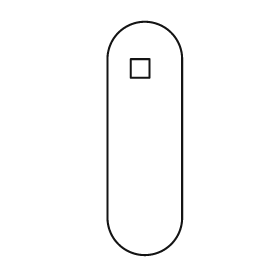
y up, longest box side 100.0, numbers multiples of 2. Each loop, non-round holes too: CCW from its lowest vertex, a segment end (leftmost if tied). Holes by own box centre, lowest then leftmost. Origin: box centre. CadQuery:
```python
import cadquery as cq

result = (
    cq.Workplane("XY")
    .moveTo(-16.0, -34.0)
    .threePointArc((0.0, -50.0), (16.0, -34.0))
    .lineTo(16.0, 34.0)
    .threePointArc((0.0, 50.0), (-16.0, 34.0))
    .close()
    .moveTo(-6.0, 26.0)
    .lineTo(2.0, 26.0)
    .lineTo(2.0, 34.0)
    .lineTo(-6.0, 34.0)
    .close()
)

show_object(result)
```